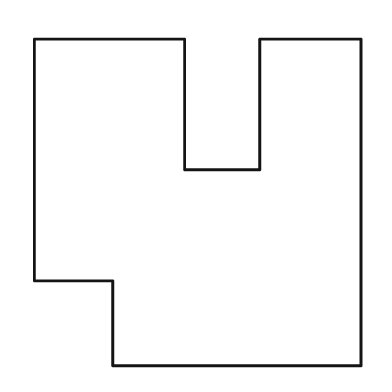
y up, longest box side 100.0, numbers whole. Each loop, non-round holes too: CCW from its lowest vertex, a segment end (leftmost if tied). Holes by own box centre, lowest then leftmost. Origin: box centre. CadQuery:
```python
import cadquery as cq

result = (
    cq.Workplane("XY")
    .moveTo(-26.0, -50.0)
    .lineTo(50.0, -50.0)
    .lineTo(50.0, 50.0)
    .lineTo(19.0, 50.0)
    .lineTo(19.0, 10.0)
    .lineTo(-4.0, 10.0)
    .lineTo(-4.0, 50.0)
    .lineTo(-50.0, 50.0)
    .lineTo(-50.0, -24.0)
    .lineTo(-26.0, -24.0)
    .close()
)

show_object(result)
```